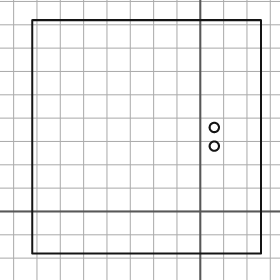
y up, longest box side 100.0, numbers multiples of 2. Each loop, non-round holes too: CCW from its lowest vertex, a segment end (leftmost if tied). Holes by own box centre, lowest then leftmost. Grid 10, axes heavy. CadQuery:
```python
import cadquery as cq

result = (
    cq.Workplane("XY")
    .moveTo(-72.0, -18.0)
    .lineTo(26.0, -18.0)
    .lineTo(26.0, 82.0)
    .lineTo(-72.0, 82.0)
    .close()
    .moveTo(6.0, 28.0)
    .circle(2.0)
    .moveTo(6.0, 36.0)
    .circle(2.0)
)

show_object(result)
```